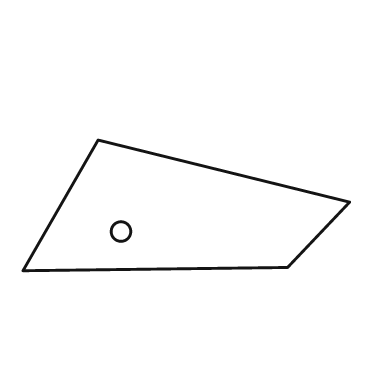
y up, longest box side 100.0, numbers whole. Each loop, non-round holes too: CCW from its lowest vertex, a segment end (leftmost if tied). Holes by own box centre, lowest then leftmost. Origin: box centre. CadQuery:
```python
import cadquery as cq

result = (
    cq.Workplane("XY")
    .moveTo(-50.0, -20.0)
    .lineTo(31.0, -19.0)
    .lineTo(50.0, 1.0)
    .lineTo(-27.0, 20.0)
    .close()
    .moveTo(-20.0, -8.0)
    .circle(3.0)
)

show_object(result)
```